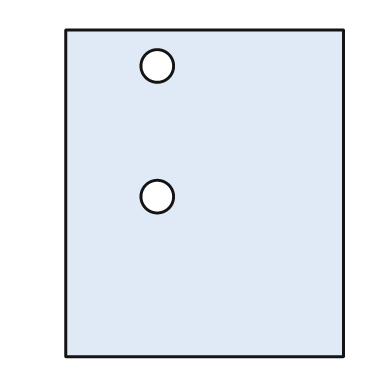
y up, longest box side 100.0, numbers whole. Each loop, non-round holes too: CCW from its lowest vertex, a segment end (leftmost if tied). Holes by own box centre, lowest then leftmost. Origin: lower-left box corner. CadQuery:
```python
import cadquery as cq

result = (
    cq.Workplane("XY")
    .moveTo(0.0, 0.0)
    .lineTo(85.0, 0.0)
    .lineTo(85.0, 100.0)
    .lineTo(0.0, 100.0)
    .close()
    .moveTo(28.0, 49.0)
    .circle(5.0)
    .moveTo(28.0, 89.0)
    .circle(5.0)
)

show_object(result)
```